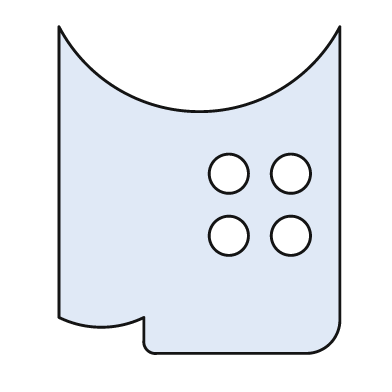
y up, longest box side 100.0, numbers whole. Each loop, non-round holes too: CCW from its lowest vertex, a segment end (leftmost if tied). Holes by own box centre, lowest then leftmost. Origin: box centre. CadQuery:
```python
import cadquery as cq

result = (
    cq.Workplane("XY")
    .moveTo(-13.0, -50.0)
    .lineTo(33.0, -50.0)
    .threePointArc((40.0, -47.0), (43.0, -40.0))
    .lineTo(43.0, 50.0)
    .threePointArc((0.0, 24.0), (-43.0, 50.0))
    .lineTo(-43.0, -39.0)
    .threePointArc((-30.0, -42.0), (-17.0, -39.0))
    .lineTo(-17.0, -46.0)
    .threePointArc((-16.0, -49.0), (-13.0, -50.0))
    .close()
    .moveTo(9.0, -14.0)
    .circle(6.0)
    .moveTo(28.0, -14.0)
    .circle(6.0)
    .moveTo(9.0, 5.0)
    .circle(6.0)
    .moveTo(28.0, 5.0)
    .circle(6.0)
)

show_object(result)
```